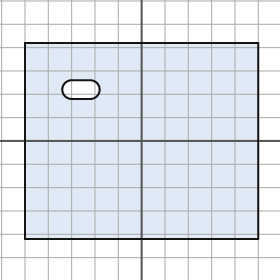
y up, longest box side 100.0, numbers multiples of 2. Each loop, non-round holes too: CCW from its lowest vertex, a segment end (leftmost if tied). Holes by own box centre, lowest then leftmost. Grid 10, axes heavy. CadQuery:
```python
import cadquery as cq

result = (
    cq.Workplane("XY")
    .moveTo(-50.0, -42.0)
    .lineTo(50.0, -42.0)
    .lineTo(50.0, 42.0)
    .lineTo(-50.0, 42.0)
    .close()
    .moveTo(-30.0, 18.0)
    .lineTo(-22.0, 18.0)
    .threePointArc((-18.0, 22.0), (-22.0, 26.0))
    .lineTo(-30.0, 26.0)
    .threePointArc((-34.0, 22.0), (-30.0, 18.0))
    .close()
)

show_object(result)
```